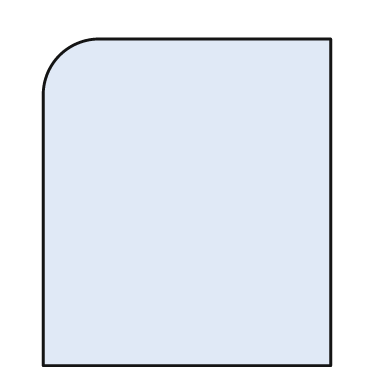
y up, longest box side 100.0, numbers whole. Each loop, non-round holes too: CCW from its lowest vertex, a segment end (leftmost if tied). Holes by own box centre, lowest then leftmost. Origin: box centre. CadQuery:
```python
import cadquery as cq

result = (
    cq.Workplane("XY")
    .moveTo(-44.0, -50.0)
    .lineTo(44.0, -50.0)
    .lineTo(44.0, 50.0)
    .lineTo(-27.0, 50.0)
    .threePointArc((-39.0, 45.0), (-44.0, 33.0))
    .close()
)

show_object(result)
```